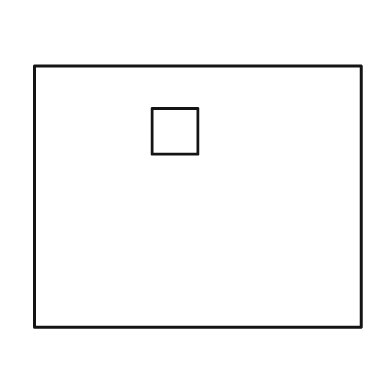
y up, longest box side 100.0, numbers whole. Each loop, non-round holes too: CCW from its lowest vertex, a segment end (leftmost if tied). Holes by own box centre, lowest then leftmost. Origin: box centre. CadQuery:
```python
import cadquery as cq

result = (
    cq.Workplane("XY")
    .moveTo(-50.0, -40.0)
    .lineTo(50.0, -40.0)
    .lineTo(50.0, 40.0)
    .lineTo(-50.0, 40.0)
    .close()
    .moveTo(-14.0, 13.0)
    .lineTo(0.0, 13.0)
    .lineTo(0.0, 27.0)
    .lineTo(-14.0, 27.0)
    .close()
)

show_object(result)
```